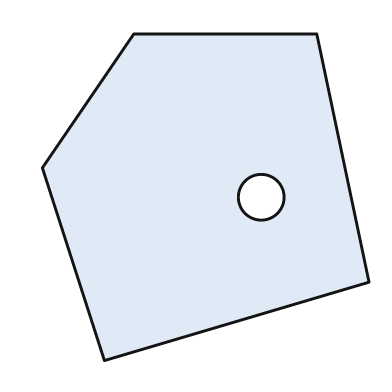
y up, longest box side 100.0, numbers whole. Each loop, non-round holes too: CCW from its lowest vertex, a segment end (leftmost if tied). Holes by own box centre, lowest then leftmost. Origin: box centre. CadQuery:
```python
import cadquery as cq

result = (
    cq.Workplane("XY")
    .moveTo(-31.0, -50.0)
    .lineTo(50.0, -26.0)
    .lineTo(34.0, 50.0)
    .lineTo(-22.0, 50.0)
    .lineTo(-50.0, 9.0)
    .close()
    .moveTo(17.0, 0.0)
    .circle(7.0)
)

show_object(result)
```